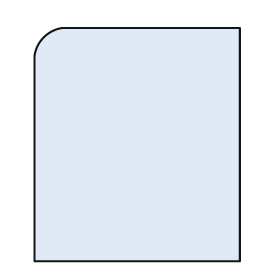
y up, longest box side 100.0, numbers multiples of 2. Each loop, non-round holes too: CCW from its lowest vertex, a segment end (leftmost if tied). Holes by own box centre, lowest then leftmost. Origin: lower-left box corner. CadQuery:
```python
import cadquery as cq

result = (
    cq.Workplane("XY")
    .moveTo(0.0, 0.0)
    .lineTo(88.0, 0.0)
    .lineTo(88.0, 100.0)
    .lineTo(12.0, 100.0)
    .threePointArc((4.0, 96.0), (0.0, 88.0))
    .close()
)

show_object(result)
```